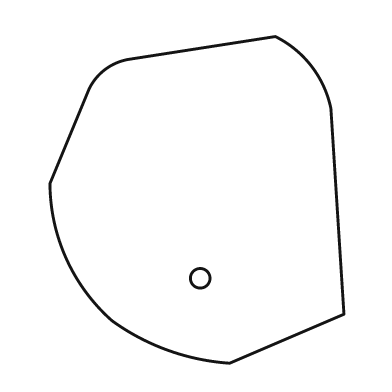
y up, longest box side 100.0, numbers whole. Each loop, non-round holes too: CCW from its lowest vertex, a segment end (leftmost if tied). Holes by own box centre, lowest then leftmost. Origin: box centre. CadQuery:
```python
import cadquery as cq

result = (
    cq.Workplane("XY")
    .moveTo(10.0, -50.0)
    .lineTo(45.0, -35.0)
    .lineTo(41.0, 28.0)
    .threePointArc((35.0, 41.0), (24.0, 50.0))
    .lineTo(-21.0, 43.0)
    .threePointArc((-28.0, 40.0), (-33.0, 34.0))
    .lineTo(-45.0, 5.0)
    .threePointArc((-40.0, -18.0), (-26.0, -37.0))
    .threePointArc((-9.0, -46.0), (10.0, -50.0))
    .close()
    .moveTo(1.0, -24.0)
    .circle(3.0)
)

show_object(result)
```